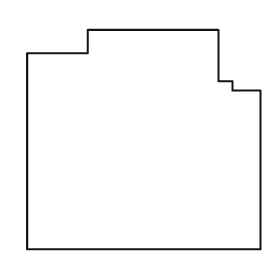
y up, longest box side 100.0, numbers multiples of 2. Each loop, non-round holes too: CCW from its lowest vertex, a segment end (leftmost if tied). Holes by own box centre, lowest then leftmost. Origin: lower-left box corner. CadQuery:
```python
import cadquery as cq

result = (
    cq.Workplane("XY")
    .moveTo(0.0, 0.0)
    .lineTo(100.0, 0.0)
    .lineTo(100.0, 68.0)
    .lineTo(88.0, 68.0)
    .lineTo(88.0, 72.0)
    .lineTo(82.0, 72.0)
    .lineTo(82.0, 94.0)
    .lineTo(26.0, 94.0)
    .lineTo(26.0, 84.0)
    .lineTo(0.0, 84.0)
    .close()
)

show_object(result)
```